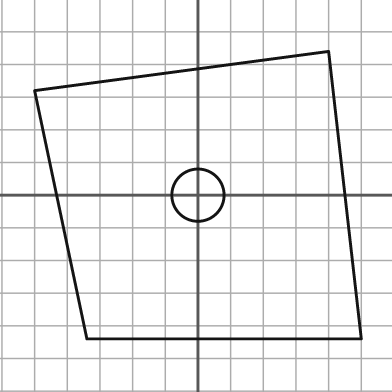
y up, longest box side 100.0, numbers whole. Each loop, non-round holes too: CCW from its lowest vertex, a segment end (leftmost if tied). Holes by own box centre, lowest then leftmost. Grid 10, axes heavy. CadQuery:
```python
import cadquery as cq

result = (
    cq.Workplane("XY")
    .moveTo(-34.0, -44.0)
    .lineTo(50.0, -44.0)
    .lineTo(40.0, 44.0)
    .lineTo(-50.0, 32.0)
    .close()
    .moveTo(0.0, 0.0)
    .circle(8.0)
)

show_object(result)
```